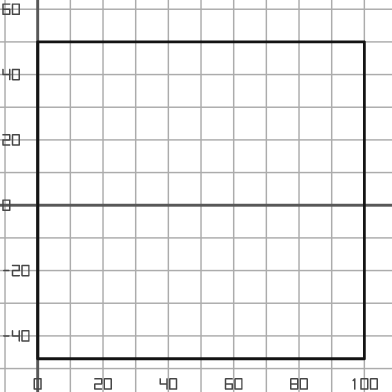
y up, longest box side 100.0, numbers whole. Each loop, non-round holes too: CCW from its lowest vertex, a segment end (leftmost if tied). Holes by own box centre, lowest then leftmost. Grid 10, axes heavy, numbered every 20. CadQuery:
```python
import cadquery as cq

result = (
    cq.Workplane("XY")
    .moveTo(0.0, -47.0)
    .lineTo(100.0, -47.0)
    .lineTo(100.0, 50.0)
    .lineTo(0.0, 50.0)
    .close()
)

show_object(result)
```